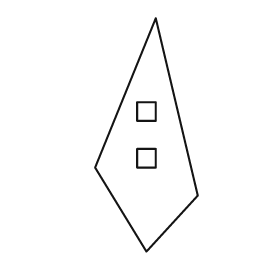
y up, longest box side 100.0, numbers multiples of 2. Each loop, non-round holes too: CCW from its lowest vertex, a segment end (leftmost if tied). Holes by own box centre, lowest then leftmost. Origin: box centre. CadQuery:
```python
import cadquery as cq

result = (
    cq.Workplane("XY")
    .moveTo(0.0, -50.0)
    .lineTo(22.0, -26.0)
    .lineTo(4.0, 50.0)
    .lineTo(-22.0, -14.0)
    .close()
    .moveTo(-4.0, -14.0)
    .lineTo(4.0, -14.0)
    .lineTo(4.0, -6.0)
    .lineTo(-4.0, -6.0)
    .close()
    .moveTo(-4.0, 6.0)
    .lineTo(4.0, 6.0)
    .lineTo(4.0, 14.0)
    .lineTo(-4.0, 14.0)
    .close()
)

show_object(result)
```